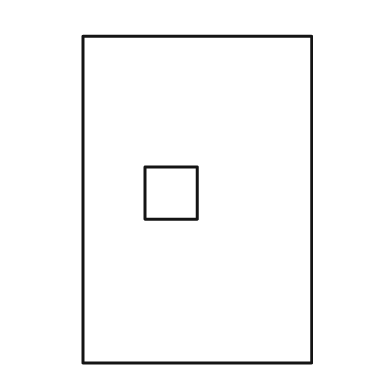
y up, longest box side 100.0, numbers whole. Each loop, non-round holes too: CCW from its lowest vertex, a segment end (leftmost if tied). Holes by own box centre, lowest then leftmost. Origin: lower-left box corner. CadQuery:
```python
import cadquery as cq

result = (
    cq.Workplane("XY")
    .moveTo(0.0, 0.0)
    .lineTo(70.0, 0.0)
    .lineTo(70.0, 100.0)
    .lineTo(0.0, 100.0)
    .close()
    .moveTo(19.0, 44.0)
    .lineTo(35.0, 44.0)
    .lineTo(35.0, 60.0)
    .lineTo(19.0, 60.0)
    .close()
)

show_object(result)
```